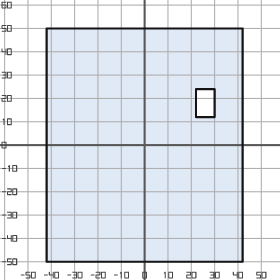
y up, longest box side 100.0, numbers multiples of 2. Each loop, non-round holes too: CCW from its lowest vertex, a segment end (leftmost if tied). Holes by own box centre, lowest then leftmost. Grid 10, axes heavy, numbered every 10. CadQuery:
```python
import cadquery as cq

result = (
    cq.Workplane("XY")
    .moveTo(-42.0, -50.0)
    .lineTo(42.0, -50.0)
    .lineTo(42.0, 50.0)
    .lineTo(-42.0, 50.0)
    .close()
    .moveTo(22.0, 12.0)
    .lineTo(30.0, 12.0)
    .lineTo(30.0, 24.0)
    .lineTo(22.0, 24.0)
    .close()
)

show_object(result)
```